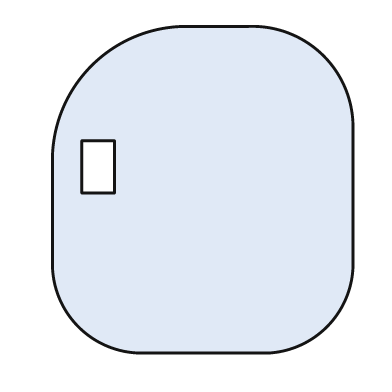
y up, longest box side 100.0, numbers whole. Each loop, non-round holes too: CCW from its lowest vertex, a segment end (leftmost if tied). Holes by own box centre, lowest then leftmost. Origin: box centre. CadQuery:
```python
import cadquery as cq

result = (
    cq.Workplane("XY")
    .moveTo(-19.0, -50.0)
    .lineTo(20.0, -50.0)
    .threePointArc((38.0, -42.0), (46.0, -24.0))
    .lineTo(46.0, 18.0)
    .threePointArc((37.0, 41.0), (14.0, 50.0))
    .lineTo(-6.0, 50.0)
    .threePointArc((-34.0, 38.0), (-46.0, 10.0))
    .lineTo(-46.0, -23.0)
    .threePointArc((-38.0, -42.0), (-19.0, -50.0))
    .close()
    .moveTo(-37.0, -1.0)
    .lineTo(-27.0, -1.0)
    .lineTo(-27.0, 15.0)
    .lineTo(-37.0, 15.0)
    .close()
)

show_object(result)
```